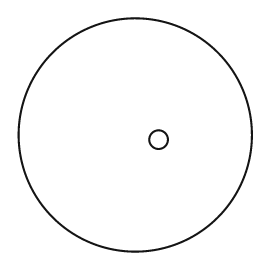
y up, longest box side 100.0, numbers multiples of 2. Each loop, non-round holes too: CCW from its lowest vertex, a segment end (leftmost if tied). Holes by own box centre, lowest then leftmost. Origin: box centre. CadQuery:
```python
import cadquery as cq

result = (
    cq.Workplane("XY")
    .moveTo(0.0, 0.0)
    .circle(50.0)
    .moveTo(10.0, -2.0)
    .circle(4.0)
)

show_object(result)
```